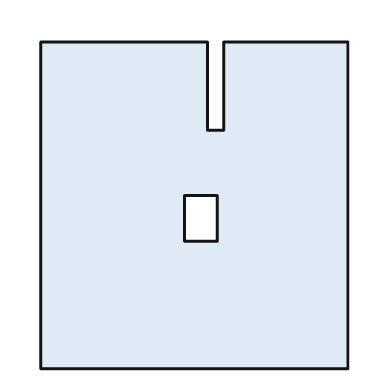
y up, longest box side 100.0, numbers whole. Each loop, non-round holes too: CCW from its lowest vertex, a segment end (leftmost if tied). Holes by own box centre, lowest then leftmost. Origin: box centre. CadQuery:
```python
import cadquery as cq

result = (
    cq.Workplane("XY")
    .moveTo(-47.0, -50.0)
    .lineTo(47.0, -50.0)
    .lineTo(47.0, 50.0)
    .lineTo(9.0, 50.0)
    .lineTo(9.0, 23.0)
    .lineTo(4.0, 23.0)
    .lineTo(4.0, 50.0)
    .lineTo(-47.0, 50.0)
    .close()
    .moveTo(-3.0, -11.0)
    .lineTo(7.0, -11.0)
    .lineTo(7.0, 3.0)
    .lineTo(-3.0, 3.0)
    .close()
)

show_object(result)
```